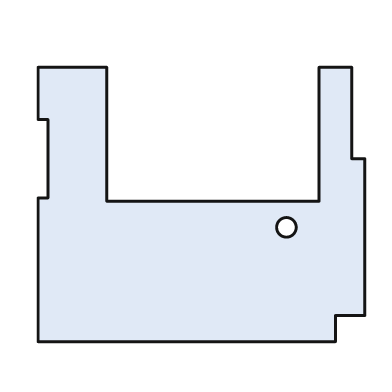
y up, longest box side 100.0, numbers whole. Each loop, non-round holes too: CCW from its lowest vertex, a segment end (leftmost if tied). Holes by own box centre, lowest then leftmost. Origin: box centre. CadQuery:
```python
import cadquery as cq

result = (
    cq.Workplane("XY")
    .moveTo(-50.0, -42.0)
    .lineTo(41.0, -42.0)
    .lineTo(41.0, -34.0)
    .lineTo(50.0, -34.0)
    .lineTo(50.0, 14.0)
    .lineTo(46.0, 14.0)
    .lineTo(46.0, 42.0)
    .lineTo(36.0, 42.0)
    .lineTo(36.0, 1.0)
    .lineTo(-29.0, 1.0)
    .lineTo(-29.0, 42.0)
    .lineTo(-50.0, 42.0)
    .lineTo(-50.0, 26.0)
    .lineTo(-47.0, 26.0)
    .lineTo(-47.0, 2.0)
    .lineTo(-50.0, 2.0)
    .close()
    .moveTo(26.0, -7.0)
    .circle(3.0)
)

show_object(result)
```